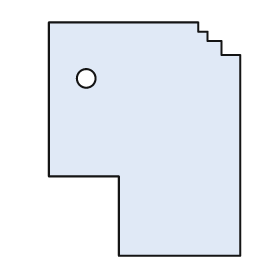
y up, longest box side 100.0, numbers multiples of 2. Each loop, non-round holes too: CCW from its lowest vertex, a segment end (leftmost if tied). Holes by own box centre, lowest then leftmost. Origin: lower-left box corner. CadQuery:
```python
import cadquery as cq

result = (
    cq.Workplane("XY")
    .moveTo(30.0, 0.0)
    .lineTo(82.0, 0.0)
    .lineTo(82.0, 86.0)
    .lineTo(74.0, 86.0)
    .lineTo(74.0, 92.0)
    .lineTo(68.0, 92.0)
    .lineTo(68.0, 96.0)
    .lineTo(64.0, 96.0)
    .lineTo(64.0, 100.0)
    .lineTo(0.0, 100.0)
    .lineTo(0.0, 34.0)
    .lineTo(30.0, 34.0)
    .close()
    .moveTo(16.0, 76.0)
    .circle(4.0)
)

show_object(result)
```